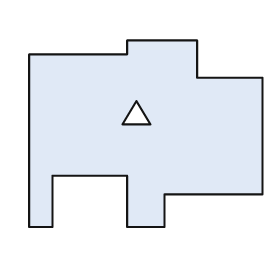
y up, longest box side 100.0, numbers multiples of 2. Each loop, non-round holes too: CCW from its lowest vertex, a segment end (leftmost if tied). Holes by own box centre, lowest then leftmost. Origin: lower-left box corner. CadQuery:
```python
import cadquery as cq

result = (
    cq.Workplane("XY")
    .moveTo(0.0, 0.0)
    .lineTo(10.0, 0.0)
    .lineTo(10.0, 22.0)
    .lineTo(42.0, 22.0)
    .lineTo(42.0, 0.0)
    .lineTo(58.0, 0.0)
    .lineTo(58.0, 14.0)
    .lineTo(100.0, 14.0)
    .lineTo(100.0, 64.0)
    .lineTo(72.0, 64.0)
    .lineTo(72.0, 80.0)
    .lineTo(42.0, 80.0)
    .lineTo(42.0, 74.0)
    .lineTo(0.0, 74.0)
    .close()
    .moveTo(40.0, 44.0)
    .lineTo(52.0, 44.0)
    .lineTo(46.0, 54.0)
    .close()
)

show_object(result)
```